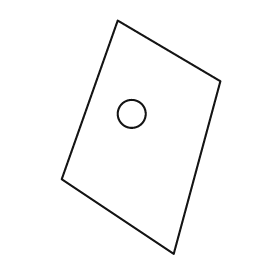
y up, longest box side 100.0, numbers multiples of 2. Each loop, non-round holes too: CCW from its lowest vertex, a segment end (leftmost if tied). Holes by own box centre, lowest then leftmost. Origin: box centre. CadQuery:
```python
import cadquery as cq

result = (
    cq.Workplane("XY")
    .moveTo(14.0, -50.0)
    .lineTo(34.0, 24.0)
    .lineTo(-10.0, 50.0)
    .lineTo(-34.0, -18.0)
    .close()
    .moveTo(-4.0, 10.0)
    .circle(6.0)
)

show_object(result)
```